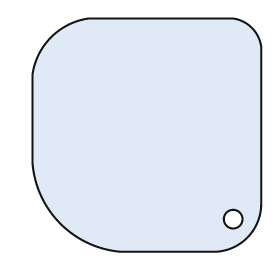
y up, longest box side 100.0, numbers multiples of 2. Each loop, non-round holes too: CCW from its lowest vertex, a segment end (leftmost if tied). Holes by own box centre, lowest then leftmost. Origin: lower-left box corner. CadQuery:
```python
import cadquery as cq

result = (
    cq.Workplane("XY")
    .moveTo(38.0, 0.0)
    .lineTo(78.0, 0.0)
    .threePointArc((92.0, 6.0), (98.0, 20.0))
    .lineTo(98.0, 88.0)
    .threePointArc((94.0, 96.0), (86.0, 100.0))
    .lineTo(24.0, 100.0)
    .threePointArc((8.0, 92.0), (0.0, 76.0))
    .lineTo(0.0, 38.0)
    .threePointArc((12.0, 12.0), (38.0, 0.0))
    .close()
    .moveTo(86.0, 14.0)
    .circle(4.0)
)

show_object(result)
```